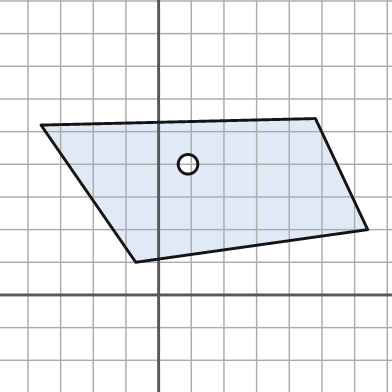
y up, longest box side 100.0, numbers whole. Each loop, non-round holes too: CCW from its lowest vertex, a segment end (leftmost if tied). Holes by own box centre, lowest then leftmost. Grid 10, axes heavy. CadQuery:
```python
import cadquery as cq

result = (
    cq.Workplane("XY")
    .moveTo(-7.0, 10.0)
    .lineTo(64.0, 20.0)
    .lineTo(48.0, 54.0)
    .lineTo(-36.0, 52.0)
    .close()
    .moveTo(9.0, 40.0)
    .circle(3.0)
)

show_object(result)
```